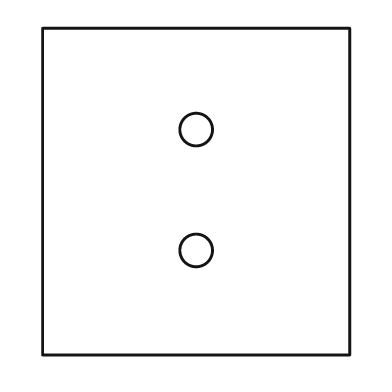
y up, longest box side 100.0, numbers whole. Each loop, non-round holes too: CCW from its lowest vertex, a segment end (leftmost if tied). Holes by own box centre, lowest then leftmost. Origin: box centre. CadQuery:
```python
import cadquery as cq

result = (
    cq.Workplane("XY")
    .moveTo(-47.0, -50.0)
    .lineTo(47.0, -50.0)
    .lineTo(47.0, 50.0)
    .lineTo(-47.0, 50.0)
    .close()
    .moveTo(0.0, -18.0)
    .circle(5.0)
    .moveTo(0.0, 19.0)
    .circle(5.0)
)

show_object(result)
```